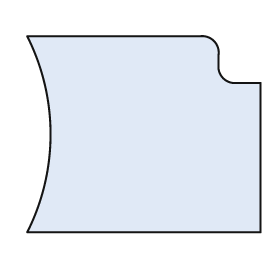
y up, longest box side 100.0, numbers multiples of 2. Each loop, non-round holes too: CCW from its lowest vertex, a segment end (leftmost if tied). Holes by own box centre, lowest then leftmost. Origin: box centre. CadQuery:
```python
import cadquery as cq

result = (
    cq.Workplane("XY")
    .moveTo(-50.0, -42.0)
    .lineTo(50.0, -42.0)
    .lineTo(50.0, 22.0)
    .lineTo(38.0, 22.0)
    .threePointArc((34.0, 24.0), (32.0, 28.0))
    .lineTo(32.0, 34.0)
    .threePointArc((30.0, 40.0), (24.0, 42.0))
    .lineTo(-50.0, 42.0)
    .threePointArc((-40.0, 0.0), (-50.0, -42.0))
    .close()
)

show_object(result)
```